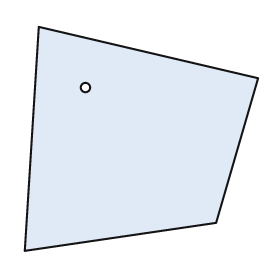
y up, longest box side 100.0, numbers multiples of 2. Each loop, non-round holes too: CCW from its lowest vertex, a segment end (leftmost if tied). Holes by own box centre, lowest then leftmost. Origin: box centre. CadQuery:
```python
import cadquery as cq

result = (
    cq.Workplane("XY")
    .moveTo(-50.0, -48.0)
    .lineTo(32.0, -36.0)
    .lineTo(50.0, 26.0)
    .lineTo(-44.0, 48.0)
    .close()
    .moveTo(-24.0, 22.0)
    .circle(2.0)
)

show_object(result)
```